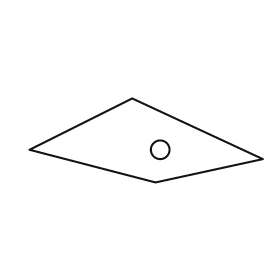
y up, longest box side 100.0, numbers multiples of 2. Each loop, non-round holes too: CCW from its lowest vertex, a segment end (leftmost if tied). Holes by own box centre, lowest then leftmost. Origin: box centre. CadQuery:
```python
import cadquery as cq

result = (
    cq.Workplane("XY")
    .moveTo(4.0, -18.0)
    .lineTo(50.0, -8.0)
    .lineTo(-6.0, 18.0)
    .lineTo(-50.0, -4.0)
    .close()
    .moveTo(6.0, -4.0)
    .circle(4.0)
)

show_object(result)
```